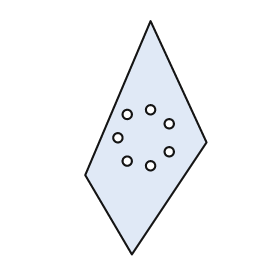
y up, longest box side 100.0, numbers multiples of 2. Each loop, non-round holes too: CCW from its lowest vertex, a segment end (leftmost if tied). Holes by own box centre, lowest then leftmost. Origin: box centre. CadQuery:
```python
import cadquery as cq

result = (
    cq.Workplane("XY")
    .moveTo(-6.0, -50.0)
    .lineTo(26.0, -2.0)
    .lineTo(2.0, 50.0)
    .lineTo(-26.0, -16.0)
    .close()
    .moveTo(2.0, -12.0)
    .circle(2.0)
    .moveTo(-8.0, -10.0)
    .circle(2.0)
    .moveTo(10.0, -6.0)
    .circle(2.0)
    .moveTo(-12.0, 0.0)
    .circle(2.0)
    .moveTo(10.0, 6.0)
    .circle(2.0)
    .moveTo(-8.0, 10.0)
    .circle(2.0)
    .moveTo(2.0, 12.0)
    .circle(2.0)
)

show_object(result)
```